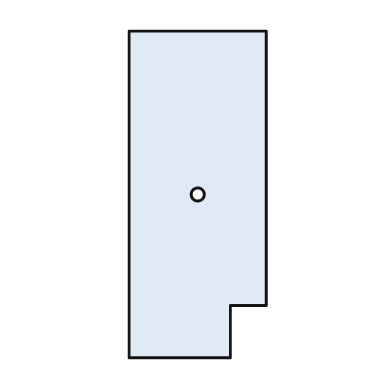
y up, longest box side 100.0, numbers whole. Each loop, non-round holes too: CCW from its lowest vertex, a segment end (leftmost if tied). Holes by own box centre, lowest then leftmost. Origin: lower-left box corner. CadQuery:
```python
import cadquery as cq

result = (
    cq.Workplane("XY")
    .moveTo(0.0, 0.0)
    .lineTo(31.0, 0.0)
    .lineTo(31.0, 16.0)
    .lineTo(42.0, 16.0)
    .lineTo(42.0, 100.0)
    .lineTo(0.0, 100.0)
    .close()
    .moveTo(21.0, 50.0)
    .circle(2.0)
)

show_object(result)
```